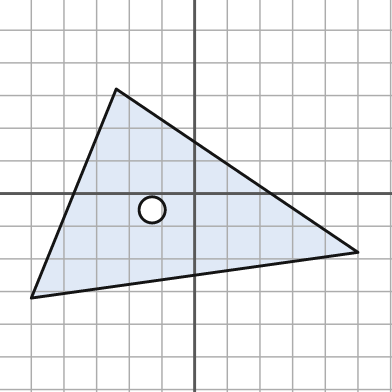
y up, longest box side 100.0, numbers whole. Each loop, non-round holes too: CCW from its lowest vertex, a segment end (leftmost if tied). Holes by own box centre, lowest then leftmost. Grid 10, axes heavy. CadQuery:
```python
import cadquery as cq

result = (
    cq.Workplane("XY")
    .moveTo(-50.0, -32.0)
    .lineTo(50.0, -18.0)
    .lineTo(-24.0, 32.0)
    .close()
    .moveTo(-13.0, -5.0)
    .circle(4.0)
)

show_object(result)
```